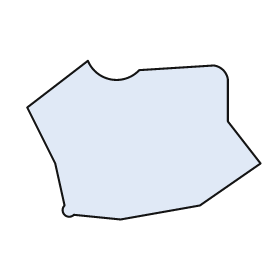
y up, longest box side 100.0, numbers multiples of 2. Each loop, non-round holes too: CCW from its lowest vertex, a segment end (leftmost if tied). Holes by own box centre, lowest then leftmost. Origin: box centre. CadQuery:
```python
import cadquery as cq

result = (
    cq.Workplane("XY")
    .moveTo(-10.0, -34.0)
    .lineTo(24.0, -28.0)
    .lineTo(50.0, -10.0)
    .lineTo(36.0, 8.0)
    .lineTo(36.0, 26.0)
    .threePointArc((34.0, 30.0), (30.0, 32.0))
    .lineTo(-2.0, 30.0)
    .threePointArc((-14.0, 26.0), (-24.0, 34.0))
    .lineTo(-50.0, 14.0)
    .lineTo(-38.0, -10.0)
    .lineTo(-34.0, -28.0)
    .threePointArc((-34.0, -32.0), (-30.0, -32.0))
    .close()
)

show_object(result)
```